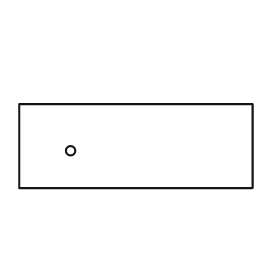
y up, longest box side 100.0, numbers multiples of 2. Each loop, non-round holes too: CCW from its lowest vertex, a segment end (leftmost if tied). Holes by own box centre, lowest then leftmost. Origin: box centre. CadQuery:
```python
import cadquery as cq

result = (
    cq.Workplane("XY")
    .moveTo(-50.0, -18.0)
    .lineTo(50.0, -18.0)
    .lineTo(50.0, 18.0)
    .lineTo(-50.0, 18.0)
    .close()
    .moveTo(-28.0, -2.0)
    .circle(2.0)
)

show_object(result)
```